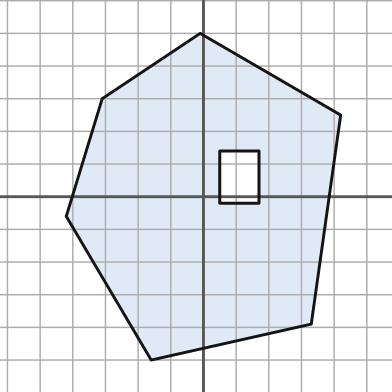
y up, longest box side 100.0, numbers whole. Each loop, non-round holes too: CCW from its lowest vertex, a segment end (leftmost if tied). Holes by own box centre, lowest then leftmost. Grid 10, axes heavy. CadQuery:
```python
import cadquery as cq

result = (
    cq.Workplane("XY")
    .moveTo(-16.0, -50.0)
    .lineTo(33.0, -39.0)
    .lineTo(42.0, 25.0)
    .lineTo(-1.0, 50.0)
    .lineTo(-31.0, 30.0)
    .lineTo(-42.0, -6.0)
    .close()
    .moveTo(5.0, -2.0)
    .lineTo(17.0, -2.0)
    .lineTo(17.0, 14.0)
    .lineTo(5.0, 14.0)
    .close()
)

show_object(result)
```